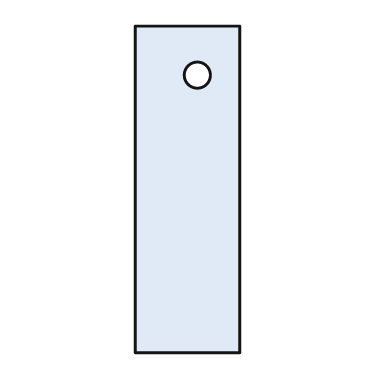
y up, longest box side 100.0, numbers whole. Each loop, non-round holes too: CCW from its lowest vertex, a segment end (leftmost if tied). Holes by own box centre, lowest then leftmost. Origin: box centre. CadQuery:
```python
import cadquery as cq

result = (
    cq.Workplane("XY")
    .moveTo(-16.0, -50.0)
    .lineTo(16.0, -50.0)
    .lineTo(16.0, 50.0)
    .lineTo(-16.0, 50.0)
    .close()
    .moveTo(3.0, 35.0)
    .circle(4.0)
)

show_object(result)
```